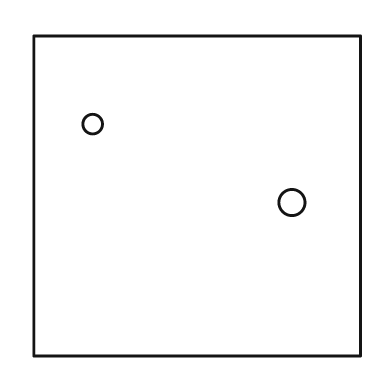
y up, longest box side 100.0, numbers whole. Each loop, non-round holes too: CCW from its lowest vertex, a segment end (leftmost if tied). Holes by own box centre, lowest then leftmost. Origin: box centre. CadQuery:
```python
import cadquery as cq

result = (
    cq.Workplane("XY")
    .moveTo(-50.0, -49.0)
    .lineTo(50.0, -49.0)
    .lineTo(50.0, 49.0)
    .lineTo(-50.0, 49.0)
    .close()
    .moveTo(29.0, -2.0)
    .circle(4.0)
    .moveTo(-32.0, 22.0)
    .circle(3.0)
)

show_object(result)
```